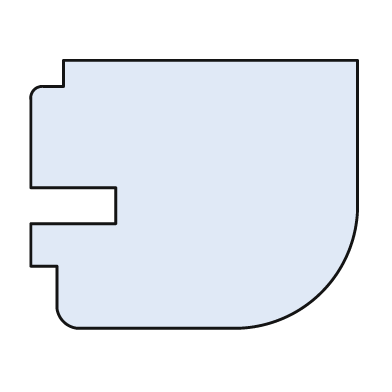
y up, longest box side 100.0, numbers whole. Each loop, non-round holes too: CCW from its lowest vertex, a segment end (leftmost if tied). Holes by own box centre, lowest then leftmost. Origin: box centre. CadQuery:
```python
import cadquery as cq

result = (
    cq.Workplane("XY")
    .moveTo(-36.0, -41.0)
    .lineTo(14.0, -41.0)
    .threePointArc((39.0, -30.0), (50.0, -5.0))
    .lineTo(50.0, 41.0)
    .lineTo(-40.0, 41.0)
    .lineTo(-40.0, 33.0)
    .lineTo(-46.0, 33.0)
    .threePointArc((-49.0, 32.0), (-50.0, 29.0))
    .lineTo(-50.0, 2.0)
    .lineTo(-24.0, 2.0)
    .lineTo(-24.0, -9.0)
    .lineTo(-50.0, -9.0)
    .lineTo(-50.0, -22.0)
    .lineTo(-42.0, -22.0)
    .lineTo(-42.0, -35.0)
    .threePointArc((-40.0, -39.0), (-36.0, -41.0))
    .close()
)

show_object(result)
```